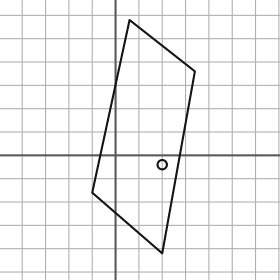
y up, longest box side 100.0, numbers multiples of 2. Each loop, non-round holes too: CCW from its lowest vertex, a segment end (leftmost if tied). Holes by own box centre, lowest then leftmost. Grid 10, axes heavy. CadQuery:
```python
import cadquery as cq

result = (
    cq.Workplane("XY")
    .moveTo(20.0, -42.0)
    .lineTo(34.0, 36.0)
    .lineTo(6.0, 58.0)
    .lineTo(-10.0, -16.0)
    .close()
    .moveTo(20.0, -4.0)
    .circle(2.0)
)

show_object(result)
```